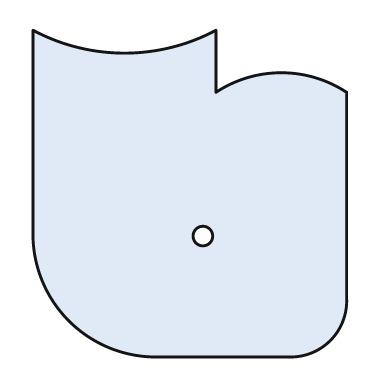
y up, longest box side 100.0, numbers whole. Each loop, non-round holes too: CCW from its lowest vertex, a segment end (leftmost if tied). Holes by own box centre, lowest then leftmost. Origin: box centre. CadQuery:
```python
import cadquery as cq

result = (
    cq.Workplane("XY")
    .moveTo(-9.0, -50.0)
    .lineTo(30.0, -50.0)
    .threePointArc((43.0, -45.0), (48.0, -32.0))
    .lineTo(48.0, 31.0)
    .threePointArc((28.0, 37.0), (8.0, 31.0))
    .lineTo(8.0, 50.0)
    .threePointArc((-20.0, 43.0), (-48.0, 50.0))
    .lineTo(-48.0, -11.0)
    .threePointArc((-37.0, -39.0), (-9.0, -50.0))
    .close()
    .moveTo(4.0, -13.0)
    .circle(3.0)
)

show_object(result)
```